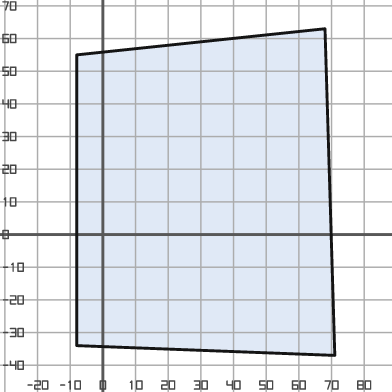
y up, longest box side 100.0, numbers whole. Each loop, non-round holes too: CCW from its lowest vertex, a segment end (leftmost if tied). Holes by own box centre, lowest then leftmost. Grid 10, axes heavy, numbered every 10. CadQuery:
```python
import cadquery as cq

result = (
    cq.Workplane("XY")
    .moveTo(71.0, -37.0)
    .lineTo(68.0, 63.0)
    .lineTo(-8.0, 55.0)
    .lineTo(-8.0, -34.0)
    .close()
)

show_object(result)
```